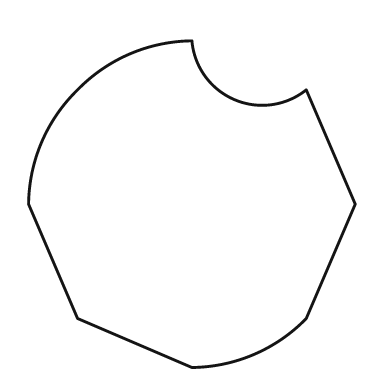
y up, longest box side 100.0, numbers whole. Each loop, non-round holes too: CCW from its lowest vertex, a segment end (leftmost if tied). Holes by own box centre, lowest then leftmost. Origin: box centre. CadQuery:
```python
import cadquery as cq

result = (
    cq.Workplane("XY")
    .moveTo(0.0, -50.0)
    .threePointArc((19.0, -46.0), (35.0, -35.0))
    .lineTo(50.0, 0.0)
    .lineTo(35.0, 35.0)
    .threePointArc((13.0, 32.0), (0.0, 50.0))
    .threePointArc((-19.0, 46.0), (-35.0, 35.0))
    .threePointArc((-46.0, 19.0), (-50.0, 0.0))
    .lineTo(-35.0, -35.0)
    .close()
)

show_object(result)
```